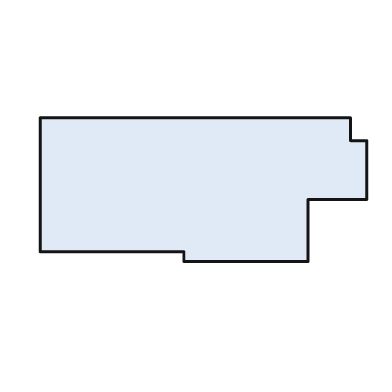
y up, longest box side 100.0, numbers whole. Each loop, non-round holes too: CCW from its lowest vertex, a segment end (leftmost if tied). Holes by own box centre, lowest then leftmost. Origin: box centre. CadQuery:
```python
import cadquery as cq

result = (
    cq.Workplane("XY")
    .moveTo(-6.0, -22.0)
    .lineTo(32.0, -22.0)
    .lineTo(32.0, -3.0)
    .lineTo(50.0, -3.0)
    .lineTo(50.0, 15.0)
    .lineTo(45.0, 15.0)
    .lineTo(45.0, 22.0)
    .lineTo(-50.0, 22.0)
    .lineTo(-50.0, -19.0)
    .lineTo(-6.0, -19.0)
    .close()
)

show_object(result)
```